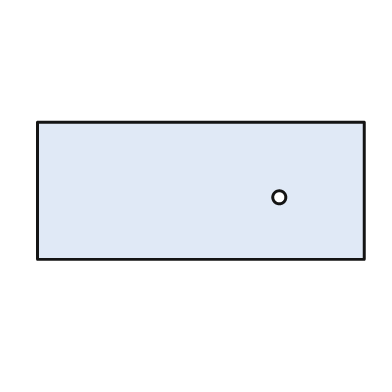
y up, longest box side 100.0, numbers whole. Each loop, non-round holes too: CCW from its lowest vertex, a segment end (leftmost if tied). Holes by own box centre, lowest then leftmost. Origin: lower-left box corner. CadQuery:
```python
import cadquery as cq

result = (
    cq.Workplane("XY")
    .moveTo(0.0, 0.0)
    .lineTo(100.0, 0.0)
    .lineTo(100.0, 42.0)
    .lineTo(0.0, 42.0)
    .close()
    .moveTo(74.0, 19.0)
    .circle(2.0)
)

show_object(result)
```